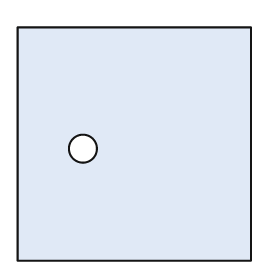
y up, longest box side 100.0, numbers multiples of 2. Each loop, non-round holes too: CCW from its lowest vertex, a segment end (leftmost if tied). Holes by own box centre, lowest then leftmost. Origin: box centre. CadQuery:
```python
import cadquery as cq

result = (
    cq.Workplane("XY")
    .moveTo(-50.0, -50.0)
    .lineTo(50.0, -50.0)
    .lineTo(50.0, 50.0)
    .lineTo(-50.0, 50.0)
    .close()
    .moveTo(-22.0, -2.0)
    .circle(6.0)
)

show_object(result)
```